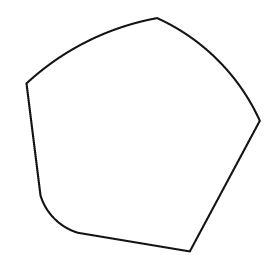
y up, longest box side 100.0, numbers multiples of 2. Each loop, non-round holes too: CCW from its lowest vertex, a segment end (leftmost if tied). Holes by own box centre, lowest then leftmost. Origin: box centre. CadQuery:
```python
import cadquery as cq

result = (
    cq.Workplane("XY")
    .moveTo(20.0, -50.0)
    .lineTo(50.0, 6.0)
    .threePointArc((32.0, 32.0), (6.0, 50.0))
    .threePointArc((-24.0, 40.0), (-50.0, 22.0))
    .lineTo(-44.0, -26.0)
    .threePointArc((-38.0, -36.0), (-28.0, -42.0))
    .close()
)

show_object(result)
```